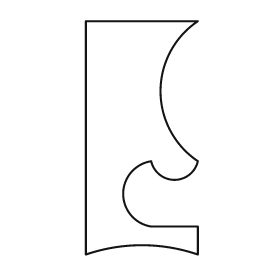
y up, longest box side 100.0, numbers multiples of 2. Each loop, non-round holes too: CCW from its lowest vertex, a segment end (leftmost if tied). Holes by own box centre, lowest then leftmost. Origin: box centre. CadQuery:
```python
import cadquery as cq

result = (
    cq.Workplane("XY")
    .moveTo(-24.0, -50.0)
    .threePointArc((0.0, -46.0), (24.0, -50.0))
    .lineTo(24.0, -38.0)
    .lineTo(4.0, -38.0)
    .threePointArc((-8.0, -24.0), (4.0, -10.0))
    .threePointArc((14.0, -18.0), (24.0, -10.0))
    .threePointArc((8.0, 20.0), (24.0, 50.0))
    .lineTo(-24.0, 50.0)
    .close()
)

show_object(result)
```